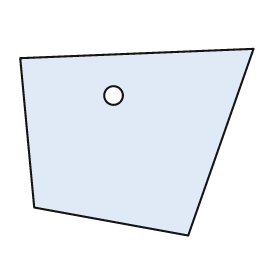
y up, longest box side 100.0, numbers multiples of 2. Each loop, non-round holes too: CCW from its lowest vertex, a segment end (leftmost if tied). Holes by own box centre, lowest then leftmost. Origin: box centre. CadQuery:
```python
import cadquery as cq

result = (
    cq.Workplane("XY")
    .moveTo(22.0, -40.0)
    .lineTo(50.0, 40.0)
    .lineTo(-50.0, 36.0)
    .lineTo(-44.0, -28.0)
    .close()
    .moveTo(-10.0, 20.0)
    .circle(4.0)
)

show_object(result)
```